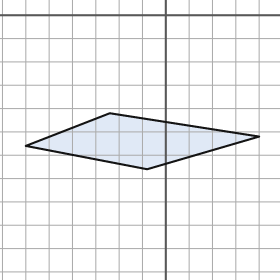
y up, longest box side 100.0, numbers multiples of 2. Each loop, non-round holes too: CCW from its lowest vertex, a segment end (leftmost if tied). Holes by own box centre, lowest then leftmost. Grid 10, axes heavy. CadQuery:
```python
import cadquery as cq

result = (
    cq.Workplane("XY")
    .moveTo(-8.0, -66.0)
    .lineTo(40.0, -52.0)
    .lineTo(-24.0, -42.0)
    .lineTo(-60.0, -56.0)
    .close()
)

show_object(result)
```